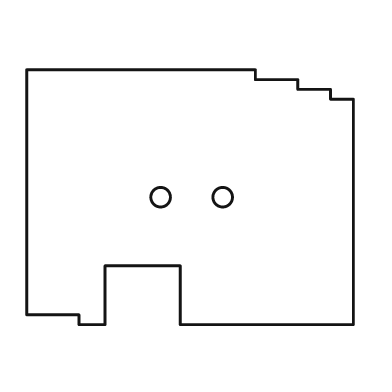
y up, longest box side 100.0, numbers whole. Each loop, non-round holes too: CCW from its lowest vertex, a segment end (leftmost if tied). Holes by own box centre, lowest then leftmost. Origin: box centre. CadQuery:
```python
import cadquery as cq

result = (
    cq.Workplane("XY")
    .moveTo(-34.0, -39.0)
    .lineTo(-26.0, -39.0)
    .lineTo(-26.0, -21.0)
    .lineTo(-3.0, -21.0)
    .lineTo(-3.0, -39.0)
    .lineTo(50.0, -39.0)
    .lineTo(50.0, 30.0)
    .lineTo(43.0, 30.0)
    .lineTo(43.0, 33.0)
    .lineTo(33.0, 33.0)
    .lineTo(33.0, 36.0)
    .lineTo(20.0, 36.0)
    .lineTo(20.0, 39.0)
    .lineTo(-50.0, 39.0)
    .lineTo(-50.0, -36.0)
    .lineTo(-34.0, -36.0)
    .close()
    .moveTo(-9.0, 0.0)
    .circle(3.0)
    .moveTo(10.0, 0.0)
    .circle(3.0)
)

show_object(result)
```